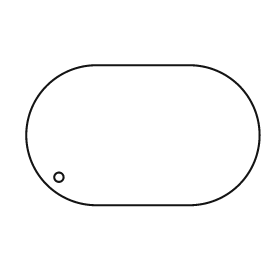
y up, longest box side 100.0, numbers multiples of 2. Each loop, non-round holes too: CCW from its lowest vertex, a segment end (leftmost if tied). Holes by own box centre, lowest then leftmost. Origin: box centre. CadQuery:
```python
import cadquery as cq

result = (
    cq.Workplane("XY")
    .moveTo(-20.0, -30.0)
    .lineTo(20.0, -30.0)
    .threePointArc((50.0, 0.0), (20.0, 30.0))
    .lineTo(-20.0, 30.0)
    .threePointArc((-50.0, 0.0), (-20.0, -30.0))
    .close()
    .moveTo(-36.0, -18.0)
    .circle(2.0)
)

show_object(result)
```